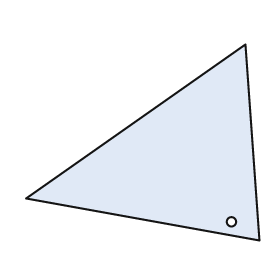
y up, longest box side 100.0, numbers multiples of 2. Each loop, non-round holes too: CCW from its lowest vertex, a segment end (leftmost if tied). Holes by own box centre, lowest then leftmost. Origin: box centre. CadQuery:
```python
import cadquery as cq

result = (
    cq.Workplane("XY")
    .moveTo(50.0, -42.0)
    .lineTo(44.0, 42.0)
    .lineTo(-50.0, -24.0)
    .close()
    .moveTo(38.0, -34.0)
    .circle(2.0)
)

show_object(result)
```